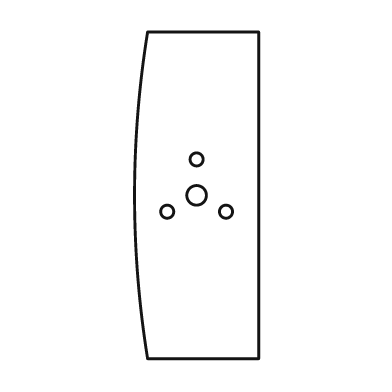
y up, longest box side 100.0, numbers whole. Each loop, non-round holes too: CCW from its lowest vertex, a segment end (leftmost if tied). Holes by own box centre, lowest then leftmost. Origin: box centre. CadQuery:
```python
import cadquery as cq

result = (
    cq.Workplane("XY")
    .moveTo(-15.0, -50.0)
    .lineTo(19.0, -50.0)
    .lineTo(19.0, 50.0)
    .lineTo(-15.0, 50.0)
    .threePointArc((-19.0, 0.0), (-15.0, -50.0))
    .close()
    .moveTo(-9.0, -5.0)
    .circle(2.0)
    .moveTo(9.0, -5.0)
    .circle(2.0)
    .moveTo(0.0, 0.0)
    .circle(3.0)
    .moveTo(0.0, 11.0)
    .circle(2.0)
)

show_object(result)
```